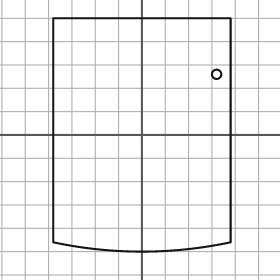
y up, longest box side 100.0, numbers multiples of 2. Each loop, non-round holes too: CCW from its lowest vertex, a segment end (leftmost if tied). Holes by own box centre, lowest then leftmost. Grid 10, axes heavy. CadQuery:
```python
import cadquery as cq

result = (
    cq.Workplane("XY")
    .moveTo(-38.0, -46.0)
    .threePointArc((0.0, -50.0), (38.0, -46.0))
    .lineTo(38.0, 50.0)
    .lineTo(-38.0, 50.0)
    .close()
    .moveTo(32.0, 26.0)
    .circle(2.0)
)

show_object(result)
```